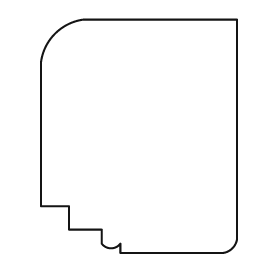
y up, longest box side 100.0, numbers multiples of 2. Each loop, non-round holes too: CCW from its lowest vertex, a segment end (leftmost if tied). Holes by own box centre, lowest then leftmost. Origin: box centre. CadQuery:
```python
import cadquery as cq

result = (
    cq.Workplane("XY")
    .moveTo(-8.0, -50.0)
    .lineTo(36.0, -50.0)
    .threePointArc((40.0, -48.0), (42.0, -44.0))
    .lineTo(42.0, 50.0)
    .lineTo(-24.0, 50.0)
    .threePointArc((-36.0, 44.0), (-42.0, 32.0))
    .lineTo(-42.0, -30.0)
    .lineTo(-30.0, -30.0)
    .lineTo(-30.0, -40.0)
    .lineTo(-16.0, -40.0)
    .lineTo(-16.0, -46.0)
    .threePointArc((-12.0, -48.0), (-8.0, -46.0))
    .close()
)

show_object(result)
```